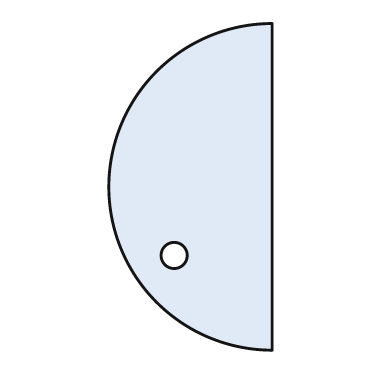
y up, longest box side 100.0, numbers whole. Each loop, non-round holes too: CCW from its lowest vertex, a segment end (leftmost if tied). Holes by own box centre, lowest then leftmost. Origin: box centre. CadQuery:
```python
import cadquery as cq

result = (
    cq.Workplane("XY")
    .moveTo(25.0, -50.0)
    .lineTo(25.0, 50.0)
    .threePointArc((-25.0, 0.0), (25.0, -50.0))
    .close()
    .moveTo(-5.0, -21.0)
    .circle(4.0)
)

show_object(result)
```